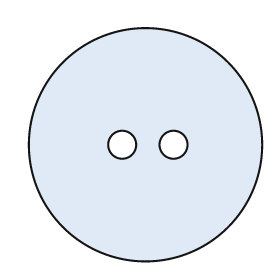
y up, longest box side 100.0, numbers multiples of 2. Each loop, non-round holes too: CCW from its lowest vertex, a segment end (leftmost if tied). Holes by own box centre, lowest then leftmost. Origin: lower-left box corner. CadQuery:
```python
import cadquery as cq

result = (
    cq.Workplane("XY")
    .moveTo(50.0, 50.0)
    .circle(50.0)
    .moveTo(40.0, 50.0)
    .circle(6.0)
    .moveTo(62.0, 50.0)
    .circle(6.0)
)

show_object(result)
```